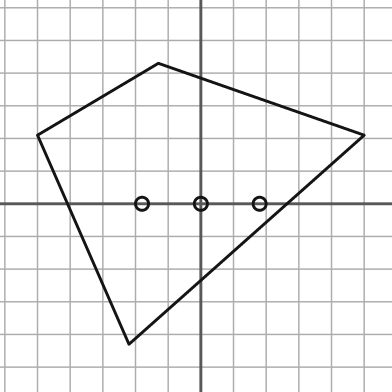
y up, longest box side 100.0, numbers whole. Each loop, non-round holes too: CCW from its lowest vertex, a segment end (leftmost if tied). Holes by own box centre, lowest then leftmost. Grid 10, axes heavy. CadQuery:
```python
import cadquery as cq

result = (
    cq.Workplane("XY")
    .moveTo(-22.0, -43.0)
    .lineTo(50.0, 21.0)
    .lineTo(-13.0, 43.0)
    .lineTo(-50.0, 21.0)
    .close()
    .moveTo(-18.0, 0.0)
    .circle(2.0)
    .moveTo(0.0, 0.0)
    .circle(2.0)
    .moveTo(18.0, 0.0)
    .circle(2.0)
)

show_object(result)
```